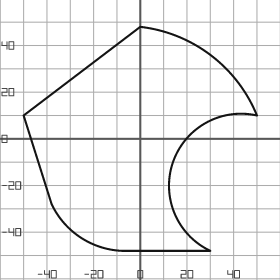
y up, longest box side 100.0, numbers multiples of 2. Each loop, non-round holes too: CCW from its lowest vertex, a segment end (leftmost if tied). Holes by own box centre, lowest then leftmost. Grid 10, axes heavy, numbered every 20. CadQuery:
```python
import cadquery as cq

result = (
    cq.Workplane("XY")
    .moveTo(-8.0, -48.0)
    .lineTo(30.0, -48.0)
    .threePointArc((14.0, -10.0), (50.0, 10.0))
    .threePointArc((30.0, 36.0), (0.0, 48.0))
    .lineTo(-50.0, 10.0)
    .lineTo(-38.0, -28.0)
    .threePointArc((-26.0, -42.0), (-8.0, -48.0))
    .close()
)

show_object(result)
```